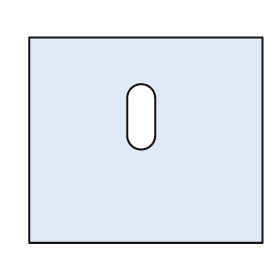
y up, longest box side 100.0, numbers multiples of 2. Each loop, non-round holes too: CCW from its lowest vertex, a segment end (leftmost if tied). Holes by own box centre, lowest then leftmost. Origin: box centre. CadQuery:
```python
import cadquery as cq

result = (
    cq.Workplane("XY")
    .moveTo(-50.0, -44.0)
    .lineTo(50.0, -44.0)
    .lineTo(50.0, 44.0)
    .lineTo(-50.0, 44.0)
    .close()
    .moveTo(-8.0, 2.0)
    .threePointArc((-2.0, -4.0), (4.0, 2.0))
    .lineTo(4.0, 18.0)
    .threePointArc((-2.0, 24.0), (-8.0, 18.0))
    .close()
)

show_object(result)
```